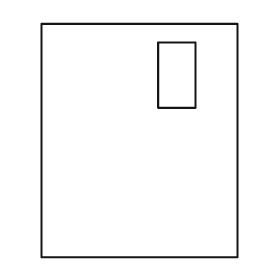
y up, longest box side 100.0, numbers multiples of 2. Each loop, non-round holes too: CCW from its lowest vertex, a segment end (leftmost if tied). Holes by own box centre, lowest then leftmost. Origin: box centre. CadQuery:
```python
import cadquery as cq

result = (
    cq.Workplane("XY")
    .moveTo(-42.0, -50.0)
    .lineTo(42.0, -50.0)
    .lineTo(42.0, 50.0)
    .lineTo(-42.0, 50.0)
    .close()
    .moveTo(8.0, 14.0)
    .lineTo(24.0, 14.0)
    .lineTo(24.0, 42.0)
    .lineTo(8.0, 42.0)
    .close()
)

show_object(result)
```